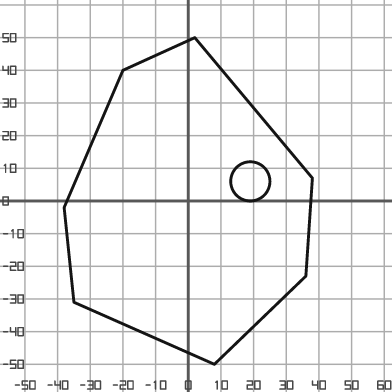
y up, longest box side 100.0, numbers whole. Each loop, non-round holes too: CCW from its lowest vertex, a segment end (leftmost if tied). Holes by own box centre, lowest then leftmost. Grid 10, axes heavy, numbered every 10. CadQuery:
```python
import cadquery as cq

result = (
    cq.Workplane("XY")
    .moveTo(8.0, -50.0)
    .lineTo(36.0, -23.0)
    .lineTo(38.0, 7.0)
    .lineTo(2.0, 50.0)
    .lineTo(-20.0, 40.0)
    .lineTo(-38.0, -2.0)
    .lineTo(-35.0, -31.0)
    .close()
    .moveTo(19.0, 6.0)
    .circle(6.0)
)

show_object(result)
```